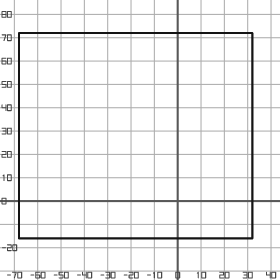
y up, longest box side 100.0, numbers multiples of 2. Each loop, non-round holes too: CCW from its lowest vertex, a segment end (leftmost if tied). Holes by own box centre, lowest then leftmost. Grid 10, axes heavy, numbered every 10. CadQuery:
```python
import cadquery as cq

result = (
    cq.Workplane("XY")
    .moveTo(-68.0, -16.0)
    .lineTo(32.0, -16.0)
    .lineTo(32.0, 72.0)
    .lineTo(-68.0, 72.0)
    .close()
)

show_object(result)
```